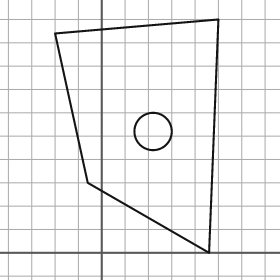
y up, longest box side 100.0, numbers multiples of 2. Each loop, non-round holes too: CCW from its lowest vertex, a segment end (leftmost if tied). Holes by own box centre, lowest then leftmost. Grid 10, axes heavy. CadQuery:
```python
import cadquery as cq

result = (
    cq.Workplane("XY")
    .moveTo(46.0, 0.0)
    .lineTo(50.0, 100.0)
    .lineTo(-20.0, 94.0)
    .lineTo(-6.0, 30.0)
    .close()
    .moveTo(22.0, 52.0)
    .circle(8.0)
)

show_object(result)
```